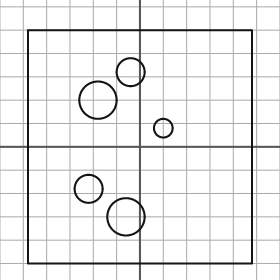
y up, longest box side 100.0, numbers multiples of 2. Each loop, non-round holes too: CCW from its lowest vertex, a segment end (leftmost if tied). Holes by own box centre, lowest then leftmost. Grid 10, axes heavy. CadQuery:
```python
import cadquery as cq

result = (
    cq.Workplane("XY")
    .moveTo(-48.0, -50.0)
    .lineTo(48.0, -50.0)
    .lineTo(48.0, 50.0)
    .lineTo(-48.0, 50.0)
    .close()
    .moveTo(-6.0, -30.0)
    .circle(8.0)
    .moveTo(-22.0, -18.0)
    .circle(6.0)
    .moveTo(10.0, 8.0)
    .circle(4.0)
    .moveTo(-18.0, 20.0)
    .circle(8.0)
    .moveTo(-4.0, 32.0)
    .circle(6.0)
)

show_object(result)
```